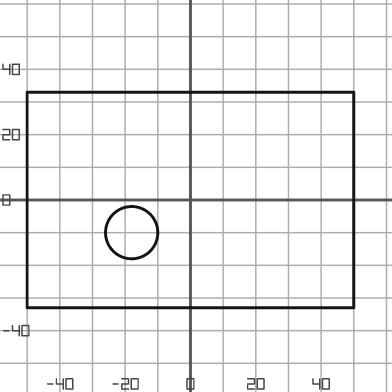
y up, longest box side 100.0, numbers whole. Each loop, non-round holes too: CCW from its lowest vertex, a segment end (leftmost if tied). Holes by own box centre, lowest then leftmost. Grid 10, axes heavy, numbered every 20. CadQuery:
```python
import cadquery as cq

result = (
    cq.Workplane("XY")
    .moveTo(-50.0, -33.0)
    .lineTo(50.0, -33.0)
    .lineTo(50.0, 33.0)
    .lineTo(-50.0, 33.0)
    .close()
    .moveTo(-18.0, -10.0)
    .circle(8.0)
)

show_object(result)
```